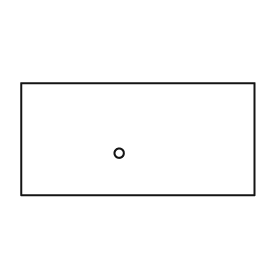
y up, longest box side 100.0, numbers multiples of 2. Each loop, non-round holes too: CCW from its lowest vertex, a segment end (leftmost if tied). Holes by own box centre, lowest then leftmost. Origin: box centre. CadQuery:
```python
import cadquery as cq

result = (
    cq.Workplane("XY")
    .moveTo(-50.0, -24.0)
    .lineTo(50.0, -24.0)
    .lineTo(50.0, 24.0)
    .lineTo(-50.0, 24.0)
    .close()
    .moveTo(-8.0, -6.0)
    .circle(2.0)
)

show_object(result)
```